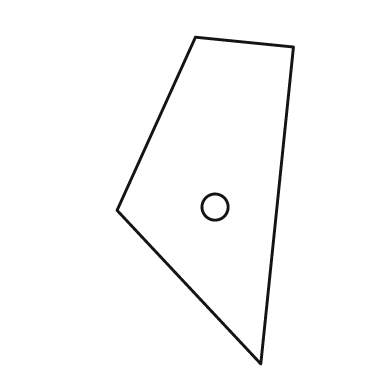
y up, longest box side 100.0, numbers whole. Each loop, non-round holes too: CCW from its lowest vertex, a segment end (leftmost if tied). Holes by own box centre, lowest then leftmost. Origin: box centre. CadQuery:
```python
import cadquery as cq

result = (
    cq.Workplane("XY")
    .moveTo(17.0, -50.0)
    .lineTo(27.0, 47.0)
    .lineTo(-3.0, 50.0)
    .lineTo(-27.0, -3.0)
    .close()
    .moveTo(3.0, -2.0)
    .circle(4.0)
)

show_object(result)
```